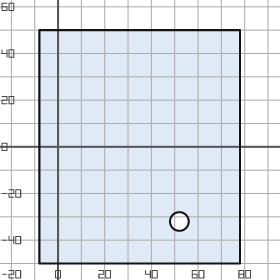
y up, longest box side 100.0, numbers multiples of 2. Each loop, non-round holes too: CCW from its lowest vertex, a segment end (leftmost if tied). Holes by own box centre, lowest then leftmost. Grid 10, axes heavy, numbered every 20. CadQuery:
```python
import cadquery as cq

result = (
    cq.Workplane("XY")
    .moveTo(-8.0, -50.0)
    .lineTo(78.0, -50.0)
    .lineTo(78.0, 50.0)
    .lineTo(-8.0, 50.0)
    .close()
    .moveTo(52.0, -32.0)
    .circle(4.0)
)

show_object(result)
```